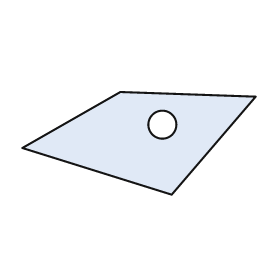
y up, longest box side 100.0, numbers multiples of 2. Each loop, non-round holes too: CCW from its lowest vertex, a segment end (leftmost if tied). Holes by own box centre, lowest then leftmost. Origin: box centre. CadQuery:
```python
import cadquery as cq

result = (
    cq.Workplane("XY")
    .moveTo(14.0, -22.0)
    .lineTo(50.0, 20.0)
    .lineTo(-8.0, 22.0)
    .lineTo(-50.0, -2.0)
    .close()
    .moveTo(10.0, 8.0)
    .circle(6.0)
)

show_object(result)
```